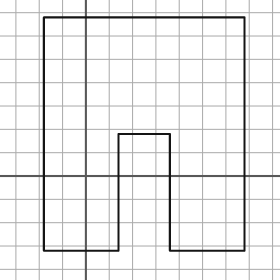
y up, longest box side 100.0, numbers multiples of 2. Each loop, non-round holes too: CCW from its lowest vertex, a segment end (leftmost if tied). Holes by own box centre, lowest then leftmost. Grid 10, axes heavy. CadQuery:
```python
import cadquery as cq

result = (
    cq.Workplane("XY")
    .moveTo(-18.0, -32.0)
    .lineTo(14.0, -32.0)
    .lineTo(14.0, 18.0)
    .lineTo(36.0, 18.0)
    .lineTo(36.0, -32.0)
    .lineTo(68.0, -32.0)
    .lineTo(68.0, 68.0)
    .lineTo(-18.0, 68.0)
    .close()
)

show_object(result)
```